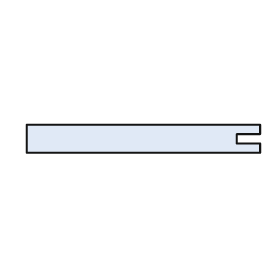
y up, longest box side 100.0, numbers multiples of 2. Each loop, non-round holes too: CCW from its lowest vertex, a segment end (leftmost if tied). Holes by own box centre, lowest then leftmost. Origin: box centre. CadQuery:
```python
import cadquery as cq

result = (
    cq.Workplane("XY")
    .moveTo(-50.0, -6.0)
    .lineTo(50.0, -6.0)
    .lineTo(50.0, -2.0)
    .lineTo(40.0, -2.0)
    .lineTo(40.0, 2.0)
    .lineTo(50.0, 2.0)
    .lineTo(50.0, 6.0)
    .lineTo(-50.0, 6.0)
    .close()
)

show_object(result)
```